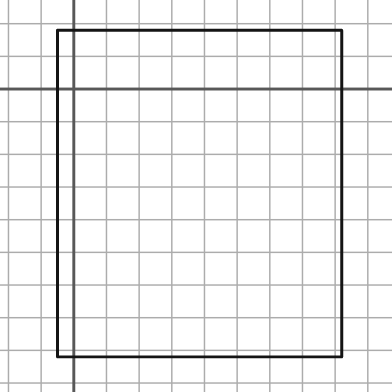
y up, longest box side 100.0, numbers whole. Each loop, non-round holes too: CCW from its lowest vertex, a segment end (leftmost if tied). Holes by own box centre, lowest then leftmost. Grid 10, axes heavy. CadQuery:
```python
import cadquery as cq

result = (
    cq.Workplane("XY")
    .moveTo(-5.0, -82.0)
    .lineTo(82.0, -82.0)
    .lineTo(82.0, 18.0)
    .lineTo(-5.0, 18.0)
    .close()
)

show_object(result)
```